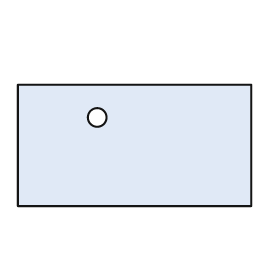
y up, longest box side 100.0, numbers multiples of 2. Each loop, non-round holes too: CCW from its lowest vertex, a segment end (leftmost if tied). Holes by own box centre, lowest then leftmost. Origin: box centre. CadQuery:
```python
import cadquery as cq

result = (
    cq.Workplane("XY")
    .moveTo(-50.0, -26.0)
    .lineTo(50.0, -26.0)
    .lineTo(50.0, 26.0)
    .lineTo(-50.0, 26.0)
    .close()
    .moveTo(-16.0, 12.0)
    .circle(4.0)
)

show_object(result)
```